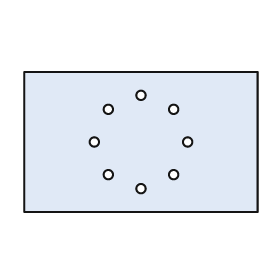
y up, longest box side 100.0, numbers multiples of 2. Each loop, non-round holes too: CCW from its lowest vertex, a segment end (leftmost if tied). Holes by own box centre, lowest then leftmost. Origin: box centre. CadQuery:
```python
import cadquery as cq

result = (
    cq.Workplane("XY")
    .moveTo(-50.0, -30.0)
    .lineTo(50.0, -30.0)
    .lineTo(50.0, 30.0)
    .lineTo(-50.0, 30.0)
    .close()
    .moveTo(0.0, -20.0)
    .circle(2.0)
    .moveTo(-14.0, -14.0)
    .circle(2.0)
    .moveTo(14.0, -14.0)
    .circle(2.0)
    .moveTo(-20.0, 0.0)
    .circle(2.0)
    .moveTo(20.0, 0.0)
    .circle(2.0)
    .moveTo(-14.0, 14.0)
    .circle(2.0)
    .moveTo(14.0, 14.0)
    .circle(2.0)
    .moveTo(0.0, 20.0)
    .circle(2.0)
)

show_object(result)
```